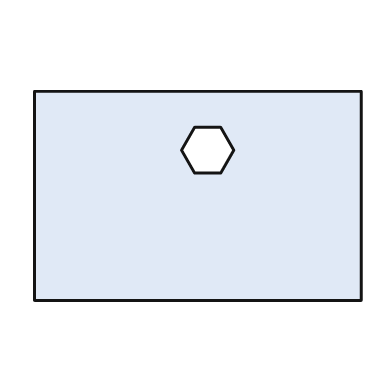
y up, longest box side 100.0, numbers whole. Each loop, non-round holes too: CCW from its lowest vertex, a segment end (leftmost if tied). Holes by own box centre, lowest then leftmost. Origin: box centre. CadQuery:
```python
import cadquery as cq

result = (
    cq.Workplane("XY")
    .moveTo(-50.0, -32.0)
    .lineTo(50.0, -32.0)
    .lineTo(50.0, 32.0)
    .lineTo(-50.0, 32.0)
    .close()
    .moveTo(-1.0, 7.0)
    .lineTo(7.0, 7.0)
    .lineTo(11.0, 14.0)
    .lineTo(7.0, 21.0)
    .lineTo(-1.0, 21.0)
    .lineTo(-5.0, 14.0)
    .close()
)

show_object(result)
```